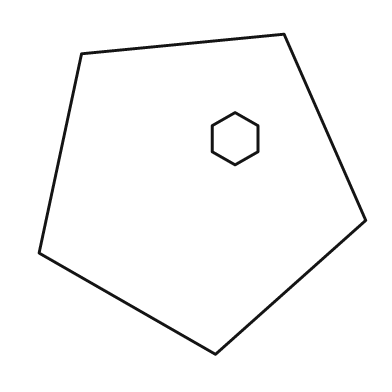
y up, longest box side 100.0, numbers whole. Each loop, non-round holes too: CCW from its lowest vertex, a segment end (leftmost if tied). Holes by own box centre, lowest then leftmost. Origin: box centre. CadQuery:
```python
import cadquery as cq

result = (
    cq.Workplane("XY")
    .moveTo(4.0, -49.0)
    .lineTo(50.0, -8.0)
    .lineTo(25.0, 49.0)
    .lineTo(-37.0, 43.0)
    .lineTo(-50.0, -18.0)
    .close()
    .moveTo(10.0, 9.0)
    .lineTo(17.0, 13.0)
    .lineTo(17.0, 21.0)
    .lineTo(10.0, 25.0)
    .lineTo(3.0, 21.0)
    .lineTo(3.0, 13.0)
    .close()
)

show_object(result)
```